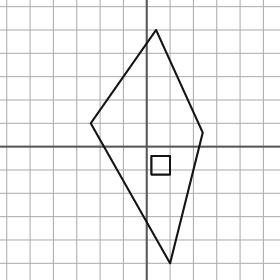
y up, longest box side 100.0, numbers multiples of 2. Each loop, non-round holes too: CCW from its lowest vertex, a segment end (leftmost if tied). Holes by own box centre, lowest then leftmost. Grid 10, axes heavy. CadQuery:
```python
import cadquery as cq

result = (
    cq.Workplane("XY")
    .moveTo(10.0, -50.0)
    .lineTo(24.0, 6.0)
    .lineTo(4.0, 50.0)
    .lineTo(-24.0, 10.0)
    .close()
    .moveTo(2.0, -12.0)
    .lineTo(10.0, -12.0)
    .lineTo(10.0, -4.0)
    .lineTo(2.0, -4.0)
    .close()
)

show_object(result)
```